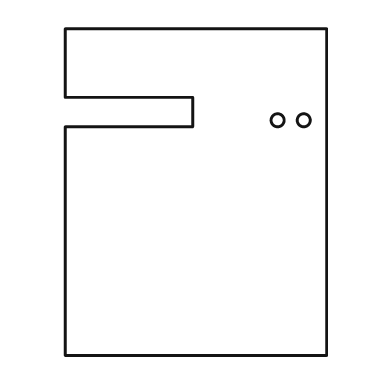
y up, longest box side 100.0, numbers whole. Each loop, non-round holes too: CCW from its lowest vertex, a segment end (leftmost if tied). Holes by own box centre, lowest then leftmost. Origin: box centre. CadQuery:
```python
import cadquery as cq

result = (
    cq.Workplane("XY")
    .moveTo(-40.0, -50.0)
    .lineTo(40.0, -50.0)
    .lineTo(40.0, 50.0)
    .lineTo(-40.0, 50.0)
    .lineTo(-40.0, 29.0)
    .lineTo(-1.0, 29.0)
    .lineTo(-1.0, 20.0)
    .lineTo(-40.0, 20.0)
    .close()
    .moveTo(25.0, 22.0)
    .circle(2.0)
    .moveTo(33.0, 22.0)
    .circle(2.0)
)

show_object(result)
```